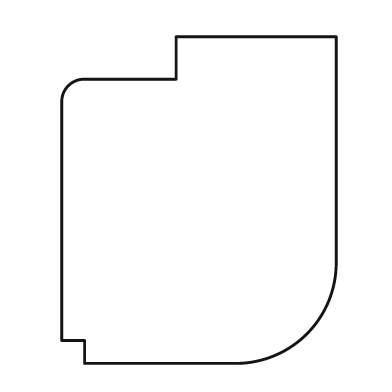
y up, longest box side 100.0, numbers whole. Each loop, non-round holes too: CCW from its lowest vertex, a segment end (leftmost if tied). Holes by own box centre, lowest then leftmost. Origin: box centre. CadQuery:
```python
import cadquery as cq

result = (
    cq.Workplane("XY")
    .moveTo(-35.0, -50.0)
    .lineTo(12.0, -50.0)
    .threePointArc((33.0, -41.0), (42.0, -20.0))
    .lineTo(42.0, 50.0)
    .lineTo(-7.0, 50.0)
    .lineTo(-7.0, 37.0)
    .lineTo(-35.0, 37.0)
    .threePointArc((-40.0, 35.0), (-42.0, 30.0))
    .lineTo(-42.0, -43.0)
    .lineTo(-35.0, -43.0)
    .close()
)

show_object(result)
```